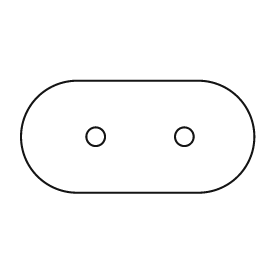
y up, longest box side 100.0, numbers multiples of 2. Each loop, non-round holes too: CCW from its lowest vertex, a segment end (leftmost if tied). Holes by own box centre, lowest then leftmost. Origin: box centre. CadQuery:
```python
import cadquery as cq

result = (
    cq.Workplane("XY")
    .moveTo(-26.0, -24.0)
    .lineTo(26.0, -24.0)
    .threePointArc((50.0, 0.0), (26.0, 24.0))
    .lineTo(-26.0, 24.0)
    .threePointArc((-50.0, 0.0), (-26.0, -24.0))
    .close()
    .moveTo(-18.0, 0.0)
    .circle(4.0)
    .moveTo(20.0, 0.0)
    .circle(4.0)
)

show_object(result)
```